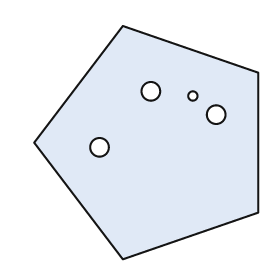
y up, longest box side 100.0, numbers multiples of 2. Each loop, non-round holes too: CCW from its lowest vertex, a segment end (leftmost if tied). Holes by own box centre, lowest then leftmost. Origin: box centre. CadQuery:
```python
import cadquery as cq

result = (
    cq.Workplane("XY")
    .moveTo(-10.0, -50.0)
    .lineTo(48.0, -30.0)
    .lineTo(48.0, 30.0)
    .lineTo(-10.0, 50.0)
    .lineTo(-48.0, 0.0)
    .close()
    .moveTo(-20.0, -2.0)
    .circle(4.0)
    .moveTo(30.0, 12.0)
    .circle(4.0)
    .moveTo(20.0, 20.0)
    .circle(2.0)
    .moveTo(2.0, 22.0)
    .circle(4.0)
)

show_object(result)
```